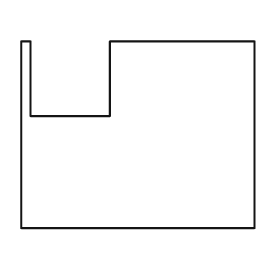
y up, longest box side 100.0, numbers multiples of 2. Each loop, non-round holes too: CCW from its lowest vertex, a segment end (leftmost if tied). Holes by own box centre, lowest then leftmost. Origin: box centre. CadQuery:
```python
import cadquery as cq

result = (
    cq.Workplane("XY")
    .moveTo(-50.0, -40.0)
    .lineTo(50.0, -40.0)
    .lineTo(50.0, 40.0)
    .lineTo(-12.0, 40.0)
    .lineTo(-12.0, 8.0)
    .lineTo(-46.0, 8.0)
    .lineTo(-46.0, 40.0)
    .lineTo(-50.0, 40.0)
    .close()
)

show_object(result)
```